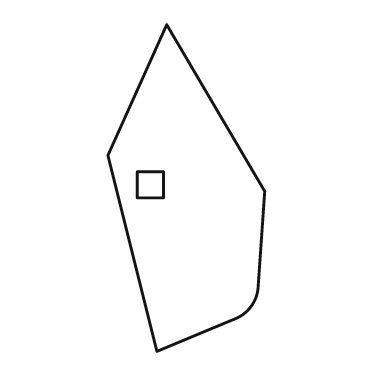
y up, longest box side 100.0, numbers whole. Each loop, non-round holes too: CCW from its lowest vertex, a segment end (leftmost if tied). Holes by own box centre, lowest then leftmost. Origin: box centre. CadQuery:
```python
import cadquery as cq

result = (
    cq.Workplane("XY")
    .moveTo(-9.0, -50.0)
    .lineTo(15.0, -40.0)
    .threePointArc((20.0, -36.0), (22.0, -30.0))
    .lineTo(24.0, -1.0)
    .lineTo(-6.0, 50.0)
    .lineTo(-24.0, 10.0)
    .close()
    .moveTo(-15.0, -3.0)
    .lineTo(-7.0, -3.0)
    .lineTo(-7.0, 5.0)
    .lineTo(-15.0, 5.0)
    .close()
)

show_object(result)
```